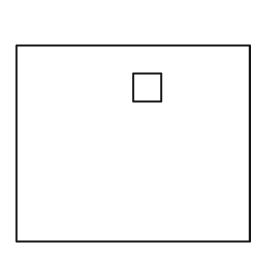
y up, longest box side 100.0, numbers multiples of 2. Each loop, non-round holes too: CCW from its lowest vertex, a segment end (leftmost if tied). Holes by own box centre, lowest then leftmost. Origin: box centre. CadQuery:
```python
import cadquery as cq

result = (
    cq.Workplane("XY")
    .moveTo(-50.0, -42.0)
    .lineTo(50.0, -42.0)
    .lineTo(50.0, 42.0)
    .lineTo(-50.0, 42.0)
    .close()
    .moveTo(0.0, 18.0)
    .lineTo(12.0, 18.0)
    .lineTo(12.0, 30.0)
    .lineTo(0.0, 30.0)
    .close()
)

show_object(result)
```